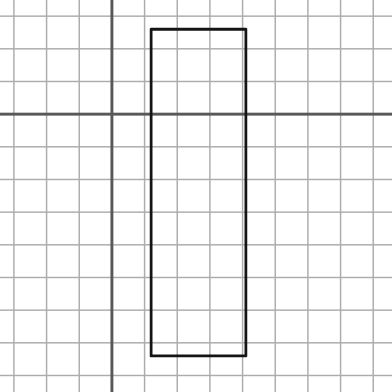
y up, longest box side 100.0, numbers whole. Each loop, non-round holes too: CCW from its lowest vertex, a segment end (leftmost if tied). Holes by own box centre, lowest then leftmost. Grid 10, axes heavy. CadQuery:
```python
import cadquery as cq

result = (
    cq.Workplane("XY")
    .moveTo(12.0, -74.0)
    .lineTo(41.0, -74.0)
    .lineTo(41.0, 26.0)
    .lineTo(12.0, 26.0)
    .close()
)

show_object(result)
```